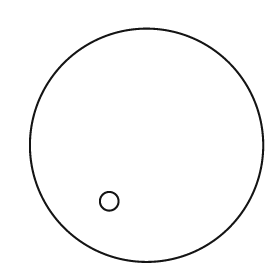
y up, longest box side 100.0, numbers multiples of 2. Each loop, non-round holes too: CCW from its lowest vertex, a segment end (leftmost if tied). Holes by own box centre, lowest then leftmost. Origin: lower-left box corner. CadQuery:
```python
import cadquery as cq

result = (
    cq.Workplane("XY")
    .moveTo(50.0, 50.0)
    .circle(50.0)
    .moveTo(34.0, 26.0)
    .circle(4.0)
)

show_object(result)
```